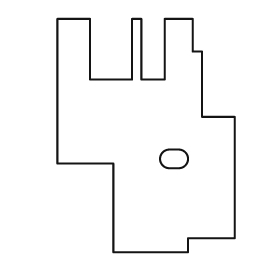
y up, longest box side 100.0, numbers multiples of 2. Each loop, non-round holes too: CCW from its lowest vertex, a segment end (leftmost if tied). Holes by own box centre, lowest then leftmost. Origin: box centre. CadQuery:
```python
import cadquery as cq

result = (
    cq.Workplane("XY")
    .moveTo(-14.0, -50.0)
    .lineTo(18.0, -50.0)
    .lineTo(18.0, -44.0)
    .lineTo(38.0, -44.0)
    .lineTo(38.0, 8.0)
    .lineTo(24.0, 8.0)
    .lineTo(24.0, 36.0)
    .lineTo(20.0, 36.0)
    .lineTo(20.0, 50.0)
    .lineTo(8.0, 50.0)
    .lineTo(8.0, 24.0)
    .lineTo(-2.0, 24.0)
    .lineTo(-2.0, 50.0)
    .lineTo(-6.0, 50.0)
    .lineTo(-6.0, 24.0)
    .lineTo(-24.0, 24.0)
    .lineTo(-24.0, 50.0)
    .lineTo(-38.0, 50.0)
    .lineTo(-38.0, -12.0)
    .lineTo(-14.0, -12.0)
    .close()
    .moveTo(10.0, -14.0)
    .lineTo(14.0, -14.0)
    .threePointArc((18.0, -10.0), (14.0, -6.0))
    .lineTo(10.0, -6.0)
    .threePointArc((6.0, -10.0), (10.0, -14.0))
    .close()
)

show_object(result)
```